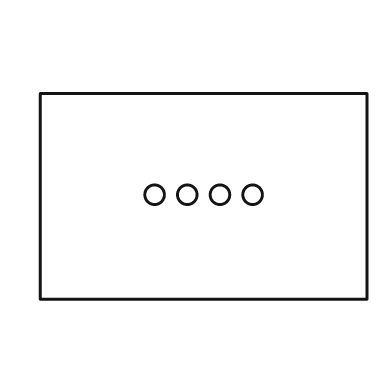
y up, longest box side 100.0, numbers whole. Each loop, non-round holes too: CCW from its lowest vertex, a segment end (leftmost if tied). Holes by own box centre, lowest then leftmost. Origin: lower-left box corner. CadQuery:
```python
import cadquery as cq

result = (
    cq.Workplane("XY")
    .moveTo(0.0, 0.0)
    .lineTo(100.0, 0.0)
    .lineTo(100.0, 63.0)
    .lineTo(0.0, 63.0)
    .close()
    .moveTo(35.0, 32.0)
    .circle(3.0)
    .moveTo(45.0, 32.0)
    .circle(3.0)
    .moveTo(55.0, 32.0)
    .circle(3.0)
    .moveTo(65.0, 32.0)
    .circle(3.0)
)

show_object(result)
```